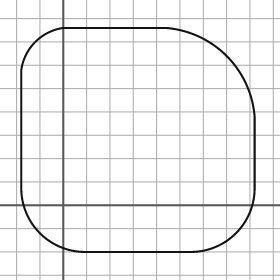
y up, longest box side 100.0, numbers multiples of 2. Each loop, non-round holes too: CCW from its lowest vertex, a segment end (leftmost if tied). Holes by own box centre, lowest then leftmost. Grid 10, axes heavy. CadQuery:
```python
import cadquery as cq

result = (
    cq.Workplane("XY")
    .moveTo(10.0, -20.0)
    .lineTo(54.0, -20.0)
    .threePointArc((74.0, -12.0), (82.0, 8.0))
    .lineTo(82.0, 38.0)
    .threePointArc((70.0, 64.0), (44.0, 76.0))
    .lineTo(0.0, 76.0)
    .threePointArc((-12.0, 70.0), (-18.0, 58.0))
    .lineTo(-18.0, 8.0)
    .threePointArc((-10.0, -12.0), (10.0, -20.0))
    .close()
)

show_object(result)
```